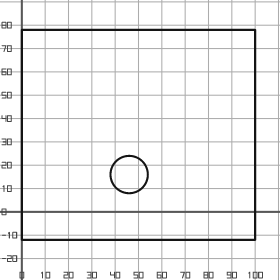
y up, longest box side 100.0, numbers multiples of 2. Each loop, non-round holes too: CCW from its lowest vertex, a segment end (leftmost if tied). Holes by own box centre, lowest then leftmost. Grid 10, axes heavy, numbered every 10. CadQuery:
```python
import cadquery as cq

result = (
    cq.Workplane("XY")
    .moveTo(0.0, -12.0)
    .lineTo(100.0, -12.0)
    .lineTo(100.0, 78.0)
    .lineTo(0.0, 78.0)
    .close()
    .moveTo(46.0, 16.0)
    .circle(8.0)
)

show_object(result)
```